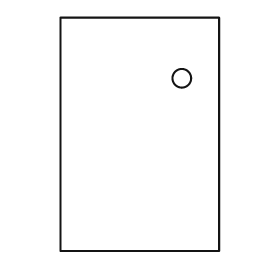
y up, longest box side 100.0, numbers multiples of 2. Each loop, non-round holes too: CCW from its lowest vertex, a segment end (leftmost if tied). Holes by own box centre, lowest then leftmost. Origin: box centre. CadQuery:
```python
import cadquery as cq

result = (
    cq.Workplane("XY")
    .moveTo(-34.0, -50.0)
    .lineTo(34.0, -50.0)
    .lineTo(34.0, 50.0)
    .lineTo(-34.0, 50.0)
    .close()
    .moveTo(18.0, 24.0)
    .circle(4.0)
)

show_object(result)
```